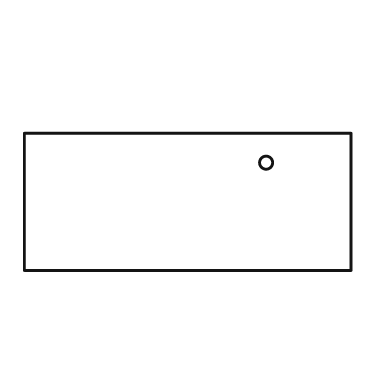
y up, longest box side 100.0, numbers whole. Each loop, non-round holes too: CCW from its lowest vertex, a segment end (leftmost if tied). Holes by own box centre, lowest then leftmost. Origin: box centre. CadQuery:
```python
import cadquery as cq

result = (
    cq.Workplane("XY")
    .moveTo(-50.0, -21.0)
    .lineTo(50.0, -21.0)
    .lineTo(50.0, 21.0)
    .lineTo(-50.0, 21.0)
    .close()
    .moveTo(24.0, 12.0)
    .circle(2.0)
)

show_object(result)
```